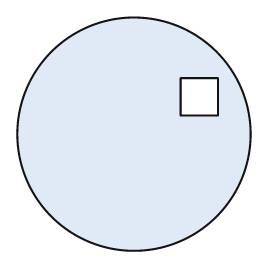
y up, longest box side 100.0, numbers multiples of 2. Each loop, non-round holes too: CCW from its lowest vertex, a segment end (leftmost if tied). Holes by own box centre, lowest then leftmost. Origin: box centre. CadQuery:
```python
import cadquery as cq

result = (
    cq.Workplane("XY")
    .moveTo(0.0, 0.0)
    .circle(50.0)
    .moveTo(20.0, 8.0)
    .lineTo(36.0, 8.0)
    .lineTo(36.0, 24.0)
    .lineTo(20.0, 24.0)
    .close()
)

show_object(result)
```